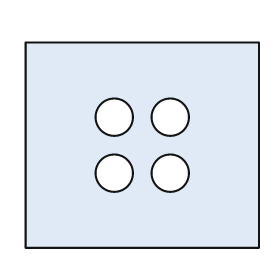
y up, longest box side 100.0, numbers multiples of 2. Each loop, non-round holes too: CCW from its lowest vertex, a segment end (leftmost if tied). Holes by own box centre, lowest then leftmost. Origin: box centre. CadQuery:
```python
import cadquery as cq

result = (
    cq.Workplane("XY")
    .moveTo(-50.0, -44.0)
    .lineTo(50.0, -44.0)
    .lineTo(50.0, 44.0)
    .lineTo(-50.0, 44.0)
    .close()
    .moveTo(-12.0, -12.0)
    .circle(8.0)
    .moveTo(12.0, -12.0)
    .circle(8.0)
    .moveTo(-12.0, 12.0)
    .circle(8.0)
    .moveTo(12.0, 12.0)
    .circle(8.0)
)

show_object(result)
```